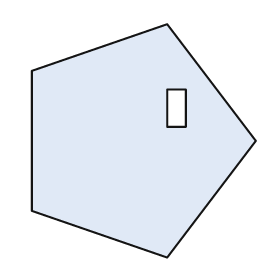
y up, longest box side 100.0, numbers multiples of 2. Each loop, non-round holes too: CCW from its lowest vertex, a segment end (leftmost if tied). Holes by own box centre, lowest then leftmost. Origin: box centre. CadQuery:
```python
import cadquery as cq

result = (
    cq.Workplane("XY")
    .moveTo(10.0, -50.0)
    .lineTo(48.0, 0.0)
    .lineTo(10.0, 50.0)
    .lineTo(-48.0, 30.0)
    .lineTo(-48.0, -30.0)
    .close()
    .moveTo(10.0, 6.0)
    .lineTo(18.0, 6.0)
    .lineTo(18.0, 22.0)
    .lineTo(10.0, 22.0)
    .close()
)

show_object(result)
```